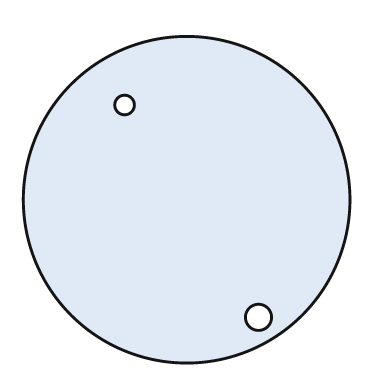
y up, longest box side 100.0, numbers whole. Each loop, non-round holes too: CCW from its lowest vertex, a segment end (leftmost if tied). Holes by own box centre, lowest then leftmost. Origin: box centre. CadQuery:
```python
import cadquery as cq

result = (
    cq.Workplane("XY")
    .moveTo(0.0, 0.0)
    .circle(50.0)
    .moveTo(22.0, -36.0)
    .circle(4.0)
    .moveTo(-19.0, 29.0)
    .circle(3.0)
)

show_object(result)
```